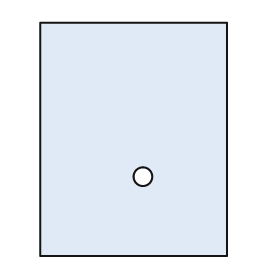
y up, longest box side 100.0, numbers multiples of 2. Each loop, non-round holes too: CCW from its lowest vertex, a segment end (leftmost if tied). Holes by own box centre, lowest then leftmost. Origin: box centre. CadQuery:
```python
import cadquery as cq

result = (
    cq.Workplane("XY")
    .moveTo(-40.0, -50.0)
    .lineTo(40.0, -50.0)
    .lineTo(40.0, 50.0)
    .lineTo(-40.0, 50.0)
    .close()
    .moveTo(4.0, -16.0)
    .circle(4.0)
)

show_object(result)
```